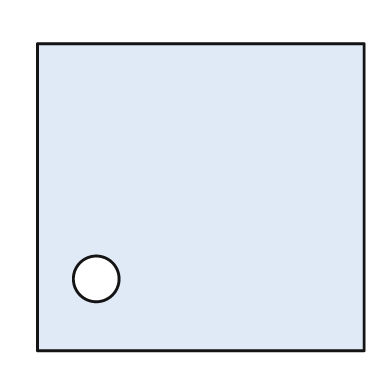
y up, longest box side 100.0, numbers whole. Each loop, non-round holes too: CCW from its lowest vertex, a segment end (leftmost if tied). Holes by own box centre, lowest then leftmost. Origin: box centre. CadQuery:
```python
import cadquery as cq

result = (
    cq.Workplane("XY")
    .moveTo(-50.0, -47.0)
    .lineTo(50.0, -47.0)
    .lineTo(50.0, 47.0)
    .lineTo(-50.0, 47.0)
    .close()
    .moveTo(-32.0, -25.0)
    .circle(7.0)
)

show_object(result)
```